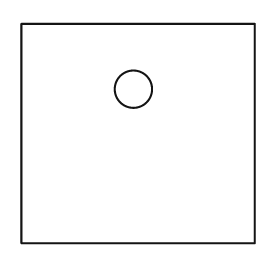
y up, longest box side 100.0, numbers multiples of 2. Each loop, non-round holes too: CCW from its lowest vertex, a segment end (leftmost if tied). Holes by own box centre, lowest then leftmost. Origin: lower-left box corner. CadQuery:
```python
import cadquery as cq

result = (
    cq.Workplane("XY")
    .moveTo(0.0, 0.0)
    .lineTo(100.0, 0.0)
    .lineTo(100.0, 94.0)
    .lineTo(0.0, 94.0)
    .close()
    .moveTo(48.0, 66.0)
    .circle(8.0)
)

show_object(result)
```